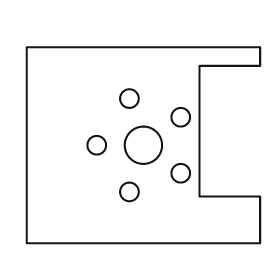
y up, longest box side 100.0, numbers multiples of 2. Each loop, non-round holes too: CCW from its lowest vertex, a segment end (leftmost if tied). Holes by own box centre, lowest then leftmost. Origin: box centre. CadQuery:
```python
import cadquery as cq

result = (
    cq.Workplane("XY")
    .moveTo(-50.0, -42.0)
    .lineTo(50.0, -42.0)
    .lineTo(50.0, -22.0)
    .lineTo(24.0, -22.0)
    .lineTo(24.0, 34.0)
    .lineTo(50.0, 34.0)
    .lineTo(50.0, 42.0)
    .lineTo(-50.0, 42.0)
    .close()
    .moveTo(-6.0, -20.0)
    .circle(4.0)
    .moveTo(16.0, -12.0)
    .circle(4.0)
    .moveTo(-20.0, 0.0)
    .circle(4.0)
    .moveTo(0.0, 0.0)
    .circle(8.0)
    .moveTo(16.0, 12.0)
    .circle(4.0)
    .moveTo(-6.0, 20.0)
    .circle(4.0)
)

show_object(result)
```